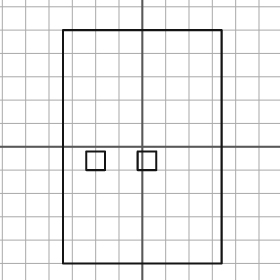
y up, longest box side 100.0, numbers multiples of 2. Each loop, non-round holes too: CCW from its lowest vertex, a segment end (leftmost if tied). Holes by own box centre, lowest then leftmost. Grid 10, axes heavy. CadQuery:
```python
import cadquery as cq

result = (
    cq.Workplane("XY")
    .moveTo(-34.0, -50.0)
    .lineTo(34.0, -50.0)
    .lineTo(34.0, 50.0)
    .lineTo(-34.0, 50.0)
    .close()
    .moveTo(-24.0, -10.0)
    .lineTo(-16.0, -10.0)
    .lineTo(-16.0, -2.0)
    .lineTo(-24.0, -2.0)
    .close()
    .moveTo(-2.0, -10.0)
    .lineTo(6.0, -10.0)
    .lineTo(6.0, -2.0)
    .lineTo(-2.0, -2.0)
    .close()
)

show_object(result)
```